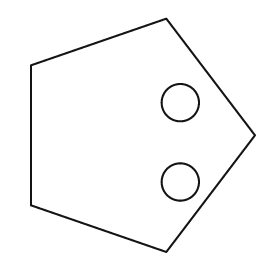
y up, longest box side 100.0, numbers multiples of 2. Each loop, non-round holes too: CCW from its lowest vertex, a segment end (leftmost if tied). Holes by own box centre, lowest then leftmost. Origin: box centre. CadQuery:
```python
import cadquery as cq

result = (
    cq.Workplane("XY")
    .moveTo(10.0, -50.0)
    .lineTo(48.0, 0.0)
    .lineTo(10.0, 50.0)
    .lineTo(-48.0, 30.0)
    .lineTo(-48.0, -30.0)
    .close()
    .moveTo(16.0, -20.0)
    .circle(8.0)
    .moveTo(16.0, 14.0)
    .circle(8.0)
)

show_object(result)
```